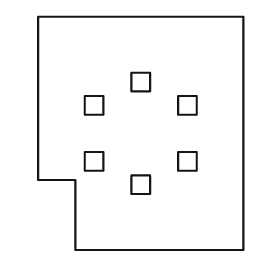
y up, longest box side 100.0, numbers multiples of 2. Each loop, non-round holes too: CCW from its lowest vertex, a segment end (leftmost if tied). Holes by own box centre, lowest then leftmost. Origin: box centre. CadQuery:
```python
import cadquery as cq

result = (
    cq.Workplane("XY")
    .moveTo(-28.0, -50.0)
    .lineTo(44.0, -50.0)
    .lineTo(44.0, 50.0)
    .lineTo(-44.0, 50.0)
    .lineTo(-44.0, -20.0)
    .lineTo(-28.0, -20.0)
    .close()
    .moveTo(-4.0, -26.0)
    .lineTo(4.0, -26.0)
    .lineTo(4.0, -18.0)
    .lineTo(-4.0, -18.0)
    .close()
    .moveTo(-24.0, -16.0)
    .lineTo(-16.0, -16.0)
    .lineTo(-16.0, -8.0)
    .lineTo(-24.0, -8.0)
    .close()
    .moveTo(16.0, -16.0)
    .lineTo(24.0, -16.0)
    .lineTo(24.0, -8.0)
    .lineTo(16.0, -8.0)
    .close()
    .moveTo(-24.0, 8.0)
    .lineTo(-16.0, 8.0)
    .lineTo(-16.0, 16.0)
    .lineTo(-24.0, 16.0)
    .close()
    .moveTo(16.0, 8.0)
    .lineTo(24.0, 8.0)
    .lineTo(24.0, 16.0)
    .lineTo(16.0, 16.0)
    .close()
    .moveTo(-4.0, 18.0)
    .lineTo(4.0, 18.0)
    .lineTo(4.0, 26.0)
    .lineTo(-4.0, 26.0)
    .close()
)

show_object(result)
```